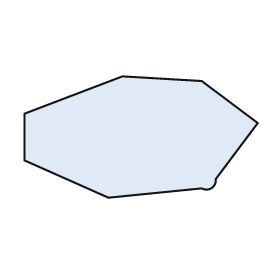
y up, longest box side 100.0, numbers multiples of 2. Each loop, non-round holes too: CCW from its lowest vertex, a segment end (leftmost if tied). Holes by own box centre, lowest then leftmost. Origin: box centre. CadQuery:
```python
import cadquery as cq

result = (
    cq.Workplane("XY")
    .moveTo(-14.0, -26.0)
    .lineTo(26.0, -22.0)
    .threePointArc((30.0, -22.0), (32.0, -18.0))
    .lineTo(50.0, 6.0)
    .lineTo(26.0, 24.0)
    .lineTo(-8.0, 26.0)
    .lineTo(-50.0, 10.0)
    .lineTo(-50.0, -10.0)
    .close()
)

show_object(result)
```